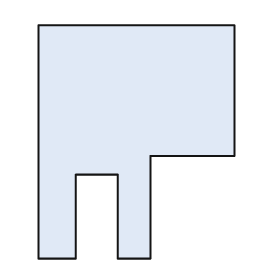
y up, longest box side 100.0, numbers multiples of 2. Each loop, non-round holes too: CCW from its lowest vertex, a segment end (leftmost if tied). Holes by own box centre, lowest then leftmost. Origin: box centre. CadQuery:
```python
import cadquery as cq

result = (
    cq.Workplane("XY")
    .moveTo(-42.0, -50.0)
    .lineTo(-26.0, -50.0)
    .lineTo(-26.0, -14.0)
    .lineTo(-8.0, -14.0)
    .lineTo(-8.0, -50.0)
    .lineTo(6.0, -50.0)
    .lineTo(6.0, -6.0)
    .lineTo(42.0, -6.0)
    .lineTo(42.0, 50.0)
    .lineTo(-42.0, 50.0)
    .close()
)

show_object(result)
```